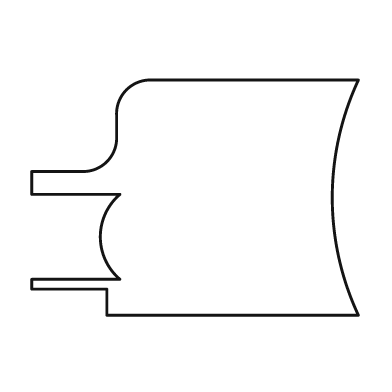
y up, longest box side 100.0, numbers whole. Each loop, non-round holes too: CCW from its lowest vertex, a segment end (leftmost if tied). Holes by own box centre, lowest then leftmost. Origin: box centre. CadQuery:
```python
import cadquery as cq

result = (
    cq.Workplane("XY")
    .moveTo(-27.0, -36.0)
    .lineTo(50.0, -36.0)
    .threePointArc((42.0, 0.0), (50.0, 36.0))
    .lineTo(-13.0, 36.0)
    .threePointArc((-21.0, 33.0), (-24.0, 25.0))
    .lineTo(-24.0, 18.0)
    .threePointArc((-27.0, 11.0), (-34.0, 8.0))
    .lineTo(-50.0, 8.0)
    .lineTo(-50.0, 1.0)
    .lineTo(-23.0, 1.0)
    .threePointArc((-29.0, -12.0), (-23.0, -25.0))
    .lineTo(-50.0, -25.0)
    .lineTo(-50.0, -28.0)
    .lineTo(-27.0, -28.0)
    .close()
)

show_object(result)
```